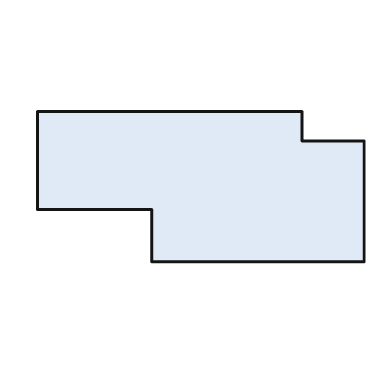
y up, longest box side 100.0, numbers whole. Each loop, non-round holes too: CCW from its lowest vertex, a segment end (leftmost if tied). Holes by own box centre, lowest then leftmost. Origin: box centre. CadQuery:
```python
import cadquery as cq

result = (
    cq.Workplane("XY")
    .moveTo(-15.0, -23.0)
    .lineTo(50.0, -23.0)
    .lineTo(50.0, 14.0)
    .lineTo(31.0, 14.0)
    .lineTo(31.0, 23.0)
    .lineTo(-50.0, 23.0)
    .lineTo(-50.0, -7.0)
    .lineTo(-15.0, -7.0)
    .close()
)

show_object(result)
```